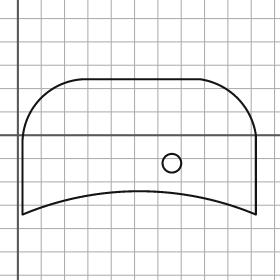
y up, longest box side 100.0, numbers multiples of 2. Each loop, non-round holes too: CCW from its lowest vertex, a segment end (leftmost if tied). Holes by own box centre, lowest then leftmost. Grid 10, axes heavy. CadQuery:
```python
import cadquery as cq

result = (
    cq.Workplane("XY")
    .moveTo(2.0, -34.0)
    .threePointArc((52.0, -24.0), (102.0, -34.0))
    .lineTo(102.0, 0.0)
    .threePointArc((94.0, 16.0), (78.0, 24.0))
    .lineTo(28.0, 24.0)
    .threePointArc((10.0, 16.0), (2.0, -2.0))
    .close()
    .moveTo(66.0, -12.0)
    .circle(4.0)
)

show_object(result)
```